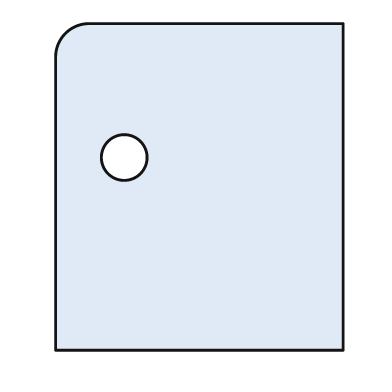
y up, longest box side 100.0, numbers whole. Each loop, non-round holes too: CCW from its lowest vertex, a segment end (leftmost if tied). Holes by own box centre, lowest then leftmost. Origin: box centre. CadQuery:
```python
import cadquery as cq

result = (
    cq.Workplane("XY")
    .moveTo(-44.0, -50.0)
    .lineTo(44.0, -50.0)
    .lineTo(44.0, 50.0)
    .lineTo(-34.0, 50.0)
    .threePointArc((-41.0, 47.0), (-44.0, 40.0))
    .close()
    .moveTo(-23.0, 9.0)
    .circle(7.0)
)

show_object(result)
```